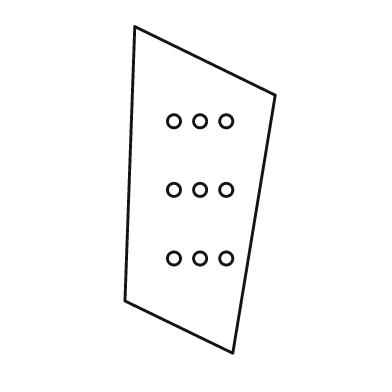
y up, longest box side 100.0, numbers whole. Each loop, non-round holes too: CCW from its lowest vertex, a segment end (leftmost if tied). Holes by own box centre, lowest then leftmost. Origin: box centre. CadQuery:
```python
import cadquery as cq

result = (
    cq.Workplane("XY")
    .moveTo(10.0, -50.0)
    .lineTo(23.0, 29.0)
    .lineTo(-20.0, 50.0)
    .lineTo(-23.0, -34.0)
    .close()
    .moveTo(-8.0, -21.0)
    .circle(2.0)
    .moveTo(0.0, -21.0)
    .circle(2.0)
    .moveTo(8.0, -21.0)
    .circle(2.0)
    .moveTo(-8.0, 0.0)
    .circle(2.0)
    .moveTo(0.0, 0.0)
    .circle(2.0)
    .moveTo(8.0, 0.0)
    .circle(2.0)
    .moveTo(-8.0, 21.0)
    .circle(2.0)
    .moveTo(0.0, 21.0)
    .circle(2.0)
    .moveTo(8.0, 21.0)
    .circle(2.0)
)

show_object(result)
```